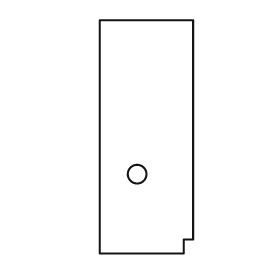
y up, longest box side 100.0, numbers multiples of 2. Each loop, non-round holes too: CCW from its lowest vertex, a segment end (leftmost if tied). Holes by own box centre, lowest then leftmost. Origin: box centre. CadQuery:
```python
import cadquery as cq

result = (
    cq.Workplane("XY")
    .moveTo(-20.0, -50.0)
    .lineTo(16.0, -50.0)
    .lineTo(16.0, -44.0)
    .lineTo(20.0, -44.0)
    .lineTo(20.0, 50.0)
    .lineTo(-20.0, 50.0)
    .close()
    .moveTo(-4.0, -16.0)
    .circle(4.0)
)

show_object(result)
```